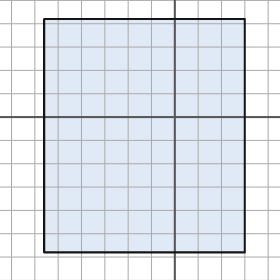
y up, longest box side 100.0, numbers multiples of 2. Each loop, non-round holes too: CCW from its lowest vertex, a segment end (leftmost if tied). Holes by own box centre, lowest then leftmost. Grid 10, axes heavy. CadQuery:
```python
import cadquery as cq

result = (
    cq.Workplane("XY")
    .moveTo(-56.0, -58.0)
    .lineTo(30.0, -58.0)
    .lineTo(30.0, 42.0)
    .lineTo(-56.0, 42.0)
    .close()
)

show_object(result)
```